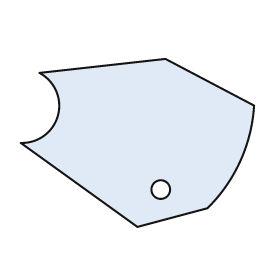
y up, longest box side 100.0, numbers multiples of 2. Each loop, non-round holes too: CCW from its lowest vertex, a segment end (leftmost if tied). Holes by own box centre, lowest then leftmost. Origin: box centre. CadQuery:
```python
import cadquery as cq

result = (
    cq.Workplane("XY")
    .moveTo(0.0, -36.0)
    .lineTo(30.0, -28.0)
    .threePointArc((44.0, -8.0), (50.0, 16.0))
    .lineTo(12.0, 36.0)
    .lineTo(-42.0, 30.0)
    .threePointArc((-34.0, 12.0), (-50.0, 0.0))
    .close()
    .moveTo(10.0, -20.0)
    .circle(4.0)
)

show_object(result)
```